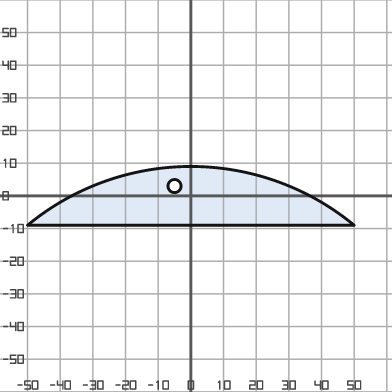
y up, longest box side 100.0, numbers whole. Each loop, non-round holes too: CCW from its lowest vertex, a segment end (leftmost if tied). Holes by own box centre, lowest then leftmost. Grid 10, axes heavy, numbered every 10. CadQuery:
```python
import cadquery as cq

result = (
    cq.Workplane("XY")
    .moveTo(-50.0, -9.0)
    .lineTo(50.0, -9.0)
    .threePointArc((0.0, 9.0), (-50.0, -9.0))
    .close()
    .moveTo(-5.0, 3.0)
    .circle(2.0)
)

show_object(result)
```